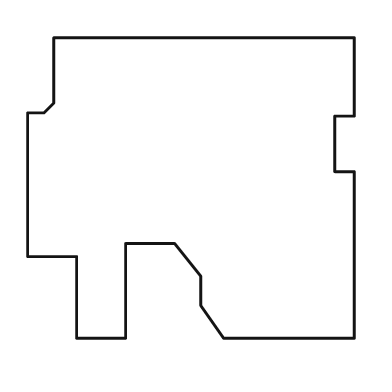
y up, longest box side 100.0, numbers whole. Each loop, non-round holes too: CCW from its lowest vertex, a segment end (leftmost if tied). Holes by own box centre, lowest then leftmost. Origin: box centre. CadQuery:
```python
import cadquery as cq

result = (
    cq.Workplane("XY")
    .moveTo(-35.0, -46.0)
    .lineTo(-20.0, -46.0)
    .lineTo(-20.0, -17.0)
    .lineTo(-5.0, -17.0)
    .lineTo(3.0, -27.0)
    .lineTo(3.0, -36.0)
    .lineTo(10.0, -46.0)
    .lineTo(50.0, -46.0)
    .lineTo(50.0, 5.0)
    .lineTo(44.0, 5.0)
    .lineTo(44.0, 22.0)
    .lineTo(50.0, 22.0)
    .lineTo(50.0, 46.0)
    .lineTo(-42.0, 46.0)
    .lineTo(-42.0, 26.0)
    .lineTo(-45.0, 23.0)
    .lineTo(-50.0, 23.0)
    .lineTo(-50.0, -21.0)
    .lineTo(-35.0, -21.0)
    .close()
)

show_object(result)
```